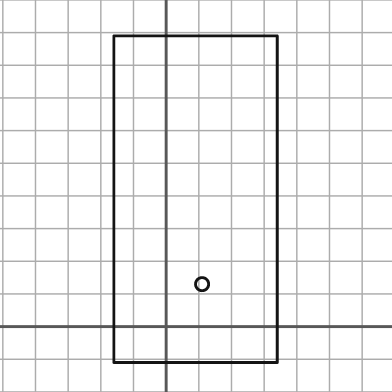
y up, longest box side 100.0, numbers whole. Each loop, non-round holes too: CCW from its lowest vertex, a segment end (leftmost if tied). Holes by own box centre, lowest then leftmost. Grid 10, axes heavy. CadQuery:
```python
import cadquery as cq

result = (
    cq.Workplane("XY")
    .moveTo(-16.0, -11.0)
    .lineTo(34.0, -11.0)
    .lineTo(34.0, 89.0)
    .lineTo(-16.0, 89.0)
    .close()
    .moveTo(11.0, 13.0)
    .circle(2.0)
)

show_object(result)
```